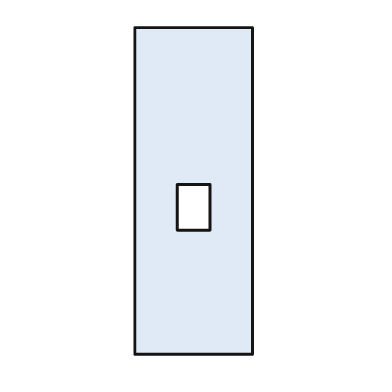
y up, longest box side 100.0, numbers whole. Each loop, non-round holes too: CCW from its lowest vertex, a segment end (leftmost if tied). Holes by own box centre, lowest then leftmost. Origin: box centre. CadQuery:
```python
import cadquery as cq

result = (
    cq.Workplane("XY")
    .moveTo(-18.0, -50.0)
    .lineTo(18.0, -50.0)
    .lineTo(18.0, 50.0)
    .lineTo(-18.0, 50.0)
    .close()
    .moveTo(-5.0, -12.0)
    .lineTo(5.0, -12.0)
    .lineTo(5.0, 2.0)
    .lineTo(-5.0, 2.0)
    .close()
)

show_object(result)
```